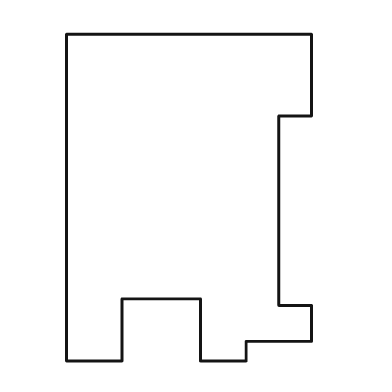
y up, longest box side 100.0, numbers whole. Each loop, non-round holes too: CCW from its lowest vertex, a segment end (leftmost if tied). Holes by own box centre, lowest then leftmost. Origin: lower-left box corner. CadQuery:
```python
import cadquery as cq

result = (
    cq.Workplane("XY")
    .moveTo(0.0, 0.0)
    .lineTo(17.0, 0.0)
    .lineTo(17.0, 19.0)
    .lineTo(41.0, 19.0)
    .lineTo(41.0, 0.0)
    .lineTo(55.0, 0.0)
    .lineTo(55.0, 6.0)
    .lineTo(75.0, 6.0)
    .lineTo(75.0, 17.0)
    .lineTo(65.0, 17.0)
    .lineTo(65.0, 75.0)
    .lineTo(75.0, 75.0)
    .lineTo(75.0, 100.0)
    .lineTo(0.0, 100.0)
    .close()
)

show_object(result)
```